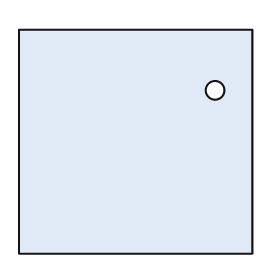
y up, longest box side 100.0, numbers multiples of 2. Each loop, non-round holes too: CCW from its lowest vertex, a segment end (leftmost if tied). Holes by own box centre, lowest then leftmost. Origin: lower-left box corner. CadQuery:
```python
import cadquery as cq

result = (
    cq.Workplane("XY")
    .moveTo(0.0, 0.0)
    .lineTo(100.0, 0.0)
    .lineTo(100.0, 96.0)
    .lineTo(0.0, 96.0)
    .close()
    .moveTo(84.0, 70.0)
    .circle(4.0)
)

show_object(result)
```